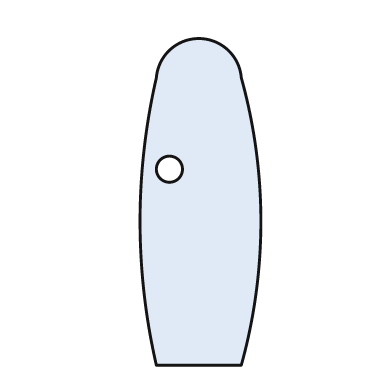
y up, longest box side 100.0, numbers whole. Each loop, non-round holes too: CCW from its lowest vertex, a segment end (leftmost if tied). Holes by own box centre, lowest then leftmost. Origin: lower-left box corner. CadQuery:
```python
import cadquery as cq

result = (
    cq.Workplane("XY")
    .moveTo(5.0, 0.0)
    .lineTo(31.0, 0.0)
    .threePointArc((37.0, 44.0), (31.0, 88.0))
    .threePointArc((18.0, 100.0), (5.0, 88.0))
    .threePointArc((0.0, 44.0), (5.0, 0.0))
    .close()
    .moveTo(9.0, 60.0)
    .circle(4.0)
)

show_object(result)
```